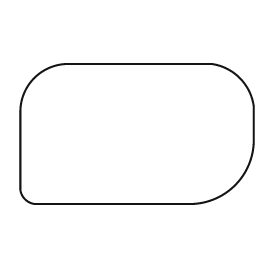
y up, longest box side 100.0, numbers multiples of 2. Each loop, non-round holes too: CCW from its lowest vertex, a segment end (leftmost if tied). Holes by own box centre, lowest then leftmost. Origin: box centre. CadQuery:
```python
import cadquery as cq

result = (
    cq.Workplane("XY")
    .moveTo(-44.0, -30.0)
    .lineTo(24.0, -30.0)
    .threePointArc((42.0, -22.0), (50.0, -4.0))
    .lineTo(50.0, 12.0)
    .threePointArc((44.0, 24.0), (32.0, 30.0))
    .lineTo(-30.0, 30.0)
    .threePointArc((-44.0, 24.0), (-50.0, 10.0))
    .lineTo(-50.0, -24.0)
    .threePointArc((-48.0, -28.0), (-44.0, -30.0))
    .close()
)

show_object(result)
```